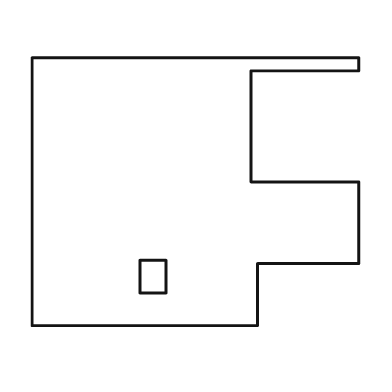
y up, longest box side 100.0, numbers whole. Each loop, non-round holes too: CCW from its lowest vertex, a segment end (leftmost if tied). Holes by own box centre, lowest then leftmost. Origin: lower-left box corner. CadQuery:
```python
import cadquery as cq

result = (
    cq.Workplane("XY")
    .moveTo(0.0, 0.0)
    .lineTo(69.0, 0.0)
    .lineTo(69.0, 19.0)
    .lineTo(100.0, 19.0)
    .lineTo(100.0, 44.0)
    .lineTo(67.0, 44.0)
    .lineTo(67.0, 78.0)
    .lineTo(100.0, 78.0)
    .lineTo(100.0, 82.0)
    .lineTo(0.0, 82.0)
    .close()
    .moveTo(33.0, 10.0)
    .lineTo(41.0, 10.0)
    .lineTo(41.0, 20.0)
    .lineTo(33.0, 20.0)
    .close()
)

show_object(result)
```